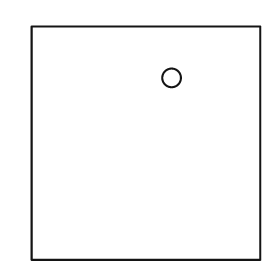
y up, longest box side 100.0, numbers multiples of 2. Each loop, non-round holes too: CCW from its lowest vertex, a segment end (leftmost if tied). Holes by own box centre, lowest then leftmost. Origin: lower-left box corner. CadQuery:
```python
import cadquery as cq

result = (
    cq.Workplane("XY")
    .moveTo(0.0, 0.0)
    .lineTo(98.0, 0.0)
    .lineTo(98.0, 100.0)
    .lineTo(0.0, 100.0)
    .close()
    .moveTo(60.0, 78.0)
    .circle(4.0)
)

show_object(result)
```